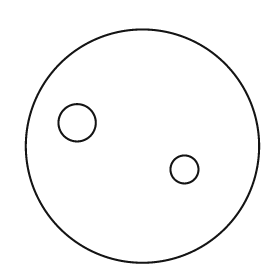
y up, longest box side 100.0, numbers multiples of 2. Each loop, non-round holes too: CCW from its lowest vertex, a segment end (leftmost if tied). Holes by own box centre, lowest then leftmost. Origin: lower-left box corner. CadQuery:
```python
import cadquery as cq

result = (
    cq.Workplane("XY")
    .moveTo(50.0, 50.0)
    .circle(50.0)
    .moveTo(68.0, 40.0)
    .circle(6.0)
    .moveTo(22.0, 60.0)
    .circle(8.0)
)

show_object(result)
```